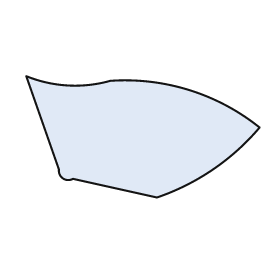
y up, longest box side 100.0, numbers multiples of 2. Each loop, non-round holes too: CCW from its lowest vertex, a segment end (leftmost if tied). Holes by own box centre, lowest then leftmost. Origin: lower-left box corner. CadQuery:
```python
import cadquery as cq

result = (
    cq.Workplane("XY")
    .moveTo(56.0, 0.0)
    .threePointArc((80.0, 12.0), (100.0, 30.0))
    .threePointArc((70.0, 46.0), (36.0, 50.0))
    .threePointArc((18.0, 48.0), (0.0, 52.0))
    .lineTo(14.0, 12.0)
    .threePointArc((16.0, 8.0), (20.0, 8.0))
    .close()
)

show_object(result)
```